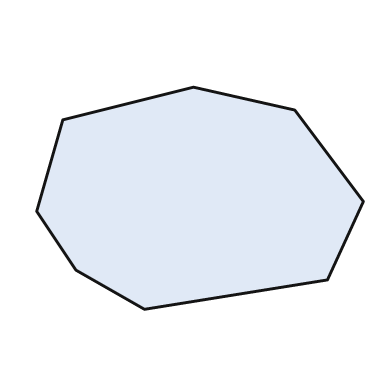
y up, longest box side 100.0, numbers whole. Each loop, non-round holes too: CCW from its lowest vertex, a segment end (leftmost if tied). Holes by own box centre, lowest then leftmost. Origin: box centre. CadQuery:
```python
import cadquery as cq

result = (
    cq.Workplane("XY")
    .moveTo(-17.0, -34.0)
    .lineTo(39.0, -25.0)
    .lineTo(50.0, -1.0)
    .lineTo(29.0, 27.0)
    .lineTo(-2.0, 34.0)
    .lineTo(-42.0, 24.0)
    .lineTo(-50.0, -4.0)
    .lineTo(-38.0, -22.0)
    .close()
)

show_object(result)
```